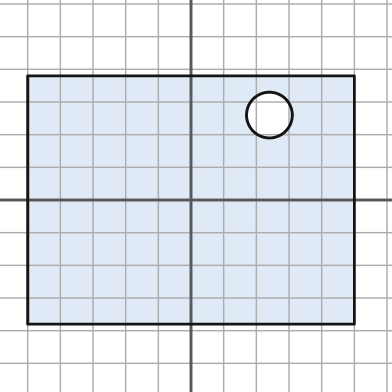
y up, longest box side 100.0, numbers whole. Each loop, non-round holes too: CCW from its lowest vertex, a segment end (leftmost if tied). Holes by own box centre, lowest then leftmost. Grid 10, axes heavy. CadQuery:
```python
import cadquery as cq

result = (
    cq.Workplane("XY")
    .moveTo(-50.0, -38.0)
    .lineTo(50.0, -38.0)
    .lineTo(50.0, 38.0)
    .lineTo(-50.0, 38.0)
    .close()
    .moveTo(24.0, 26.0)
    .circle(7.0)
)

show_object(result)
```